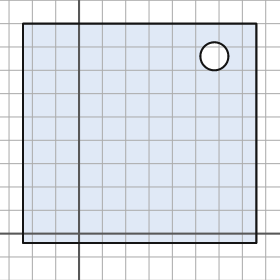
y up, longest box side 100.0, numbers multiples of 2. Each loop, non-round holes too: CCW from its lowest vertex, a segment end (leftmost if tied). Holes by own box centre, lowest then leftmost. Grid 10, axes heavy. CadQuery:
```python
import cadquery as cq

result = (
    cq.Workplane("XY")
    .moveTo(-24.0, -4.0)
    .lineTo(76.0, -4.0)
    .lineTo(76.0, 90.0)
    .lineTo(-24.0, 90.0)
    .close()
    .moveTo(58.0, 76.0)
    .circle(6.0)
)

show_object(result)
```